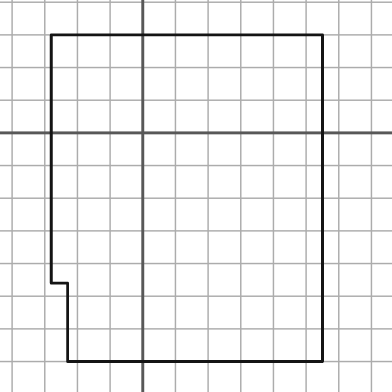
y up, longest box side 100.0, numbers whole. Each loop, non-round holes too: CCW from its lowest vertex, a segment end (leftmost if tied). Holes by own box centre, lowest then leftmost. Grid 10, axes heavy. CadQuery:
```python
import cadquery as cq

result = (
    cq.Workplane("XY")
    .moveTo(-23.0, -70.0)
    .lineTo(55.0, -70.0)
    .lineTo(55.0, 30.0)
    .lineTo(-28.0, 30.0)
    .lineTo(-28.0, -46.0)
    .lineTo(-23.0, -46.0)
    .close()
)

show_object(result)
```